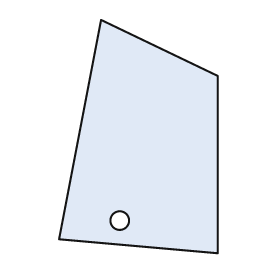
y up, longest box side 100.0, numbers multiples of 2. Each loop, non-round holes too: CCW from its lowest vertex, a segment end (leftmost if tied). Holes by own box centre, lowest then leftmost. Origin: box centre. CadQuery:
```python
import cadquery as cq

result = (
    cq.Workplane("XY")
    .moveTo(34.0, -50.0)
    .lineTo(34.0, 26.0)
    .lineTo(-16.0, 50.0)
    .lineTo(-34.0, -44.0)
    .close()
    .moveTo(-8.0, -36.0)
    .circle(4.0)
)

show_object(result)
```